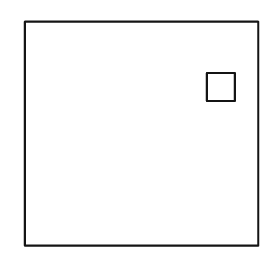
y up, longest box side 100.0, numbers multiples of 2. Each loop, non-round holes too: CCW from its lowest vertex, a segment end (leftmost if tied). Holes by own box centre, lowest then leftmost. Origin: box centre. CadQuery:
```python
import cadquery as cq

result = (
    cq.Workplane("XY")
    .moveTo(-50.0, -48.0)
    .lineTo(50.0, -48.0)
    .lineTo(50.0, 48.0)
    .lineTo(-50.0, 48.0)
    .close()
    .moveTo(28.0, 14.0)
    .lineTo(40.0, 14.0)
    .lineTo(40.0, 26.0)
    .lineTo(28.0, 26.0)
    .close()
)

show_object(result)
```